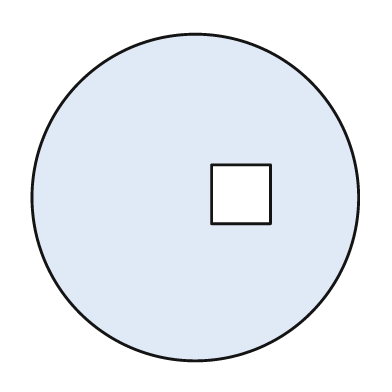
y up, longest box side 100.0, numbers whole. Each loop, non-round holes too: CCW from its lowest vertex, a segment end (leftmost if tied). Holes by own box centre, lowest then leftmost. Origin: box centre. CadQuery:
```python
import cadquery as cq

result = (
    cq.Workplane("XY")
    .moveTo(0.0, 0.0)
    .circle(50.0)
    .moveTo(5.0, -8.0)
    .lineTo(23.0, -8.0)
    .lineTo(23.0, 10.0)
    .lineTo(5.0, 10.0)
    .close()
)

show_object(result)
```